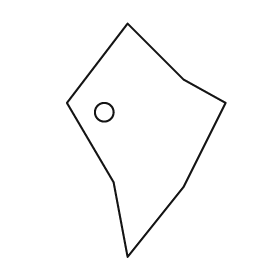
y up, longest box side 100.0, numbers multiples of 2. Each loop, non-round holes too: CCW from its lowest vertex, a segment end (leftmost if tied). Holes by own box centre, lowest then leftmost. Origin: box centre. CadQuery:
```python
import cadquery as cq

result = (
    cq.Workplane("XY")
    .moveTo(-8.0, -50.0)
    .lineTo(16.0, -20.0)
    .lineTo(34.0, 16.0)
    .lineTo(16.0, 26.0)
    .lineTo(-8.0, 50.0)
    .lineTo(-34.0, 16.0)
    .lineTo(-14.0, -18.0)
    .close()
    .moveTo(-18.0, 12.0)
    .circle(4.0)
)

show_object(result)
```